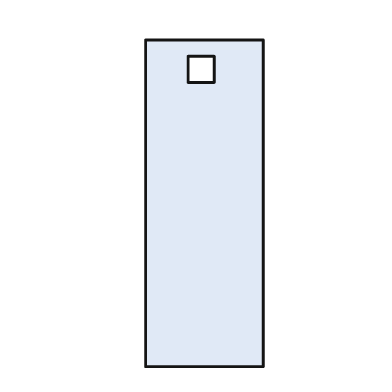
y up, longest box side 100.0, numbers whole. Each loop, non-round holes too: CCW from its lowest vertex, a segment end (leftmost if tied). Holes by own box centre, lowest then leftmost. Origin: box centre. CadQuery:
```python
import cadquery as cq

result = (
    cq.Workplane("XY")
    .moveTo(-18.0, -50.0)
    .lineTo(18.0, -50.0)
    .lineTo(18.0, 50.0)
    .lineTo(-18.0, 50.0)
    .close()
    .moveTo(-5.0, 37.0)
    .lineTo(3.0, 37.0)
    .lineTo(3.0, 45.0)
    .lineTo(-5.0, 45.0)
    .close()
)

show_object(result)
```